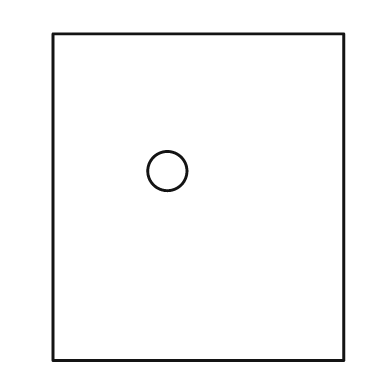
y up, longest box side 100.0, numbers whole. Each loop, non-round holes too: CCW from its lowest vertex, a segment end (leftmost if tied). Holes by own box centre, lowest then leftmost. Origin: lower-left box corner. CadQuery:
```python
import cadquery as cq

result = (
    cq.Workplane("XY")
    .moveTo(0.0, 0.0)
    .lineTo(89.0, 0.0)
    .lineTo(89.0, 100.0)
    .lineTo(0.0, 100.0)
    .close()
    .moveTo(35.0, 58.0)
    .circle(6.0)
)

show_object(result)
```